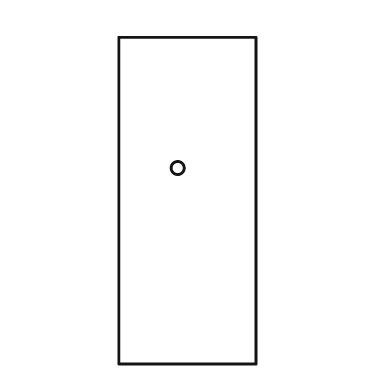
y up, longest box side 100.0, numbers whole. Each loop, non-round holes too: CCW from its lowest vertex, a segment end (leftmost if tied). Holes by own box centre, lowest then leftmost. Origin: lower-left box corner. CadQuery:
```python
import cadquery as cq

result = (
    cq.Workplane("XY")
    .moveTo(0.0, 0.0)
    .lineTo(42.0, 0.0)
    .lineTo(42.0, 100.0)
    .lineTo(0.0, 100.0)
    .close()
    .moveTo(18.0, 60.0)
    .circle(2.0)
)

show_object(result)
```